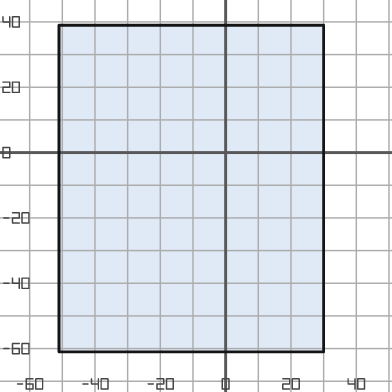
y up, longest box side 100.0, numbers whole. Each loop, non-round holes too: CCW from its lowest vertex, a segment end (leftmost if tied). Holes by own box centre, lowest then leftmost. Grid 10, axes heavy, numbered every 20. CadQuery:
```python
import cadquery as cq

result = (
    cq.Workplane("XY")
    .moveTo(-51.0, -61.0)
    .lineTo(30.0, -61.0)
    .lineTo(30.0, 39.0)
    .lineTo(-51.0, 39.0)
    .close()
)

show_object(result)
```